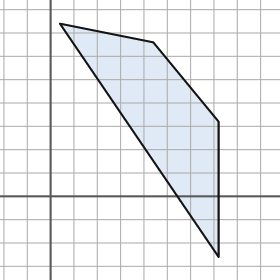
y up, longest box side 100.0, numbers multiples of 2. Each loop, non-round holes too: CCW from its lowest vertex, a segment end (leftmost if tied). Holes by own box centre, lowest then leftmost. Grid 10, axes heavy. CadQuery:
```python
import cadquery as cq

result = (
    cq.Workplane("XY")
    .moveTo(72.0, -26.0)
    .lineTo(72.0, 32.0)
    .lineTo(44.0, 66.0)
    .lineTo(4.0, 74.0)
    .close()
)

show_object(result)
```